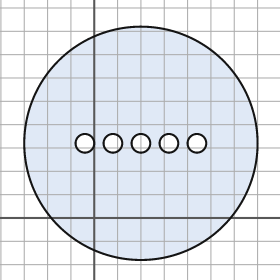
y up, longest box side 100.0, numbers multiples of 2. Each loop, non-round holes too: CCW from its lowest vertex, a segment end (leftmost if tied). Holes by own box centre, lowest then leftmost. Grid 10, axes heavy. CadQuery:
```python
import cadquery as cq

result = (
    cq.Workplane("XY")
    .moveTo(20.0, 32.0)
    .circle(50.0)
    .moveTo(-4.0, 32.0)
    .circle(4.0)
    .moveTo(8.0, 32.0)
    .circle(4.0)
    .moveTo(20.0, 32.0)
    .circle(4.0)
    .moveTo(32.0, 32.0)
    .circle(4.0)
    .moveTo(44.0, 32.0)
    .circle(4.0)
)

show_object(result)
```